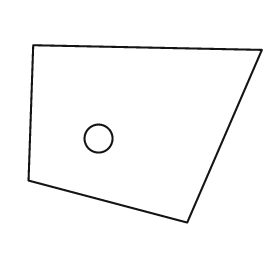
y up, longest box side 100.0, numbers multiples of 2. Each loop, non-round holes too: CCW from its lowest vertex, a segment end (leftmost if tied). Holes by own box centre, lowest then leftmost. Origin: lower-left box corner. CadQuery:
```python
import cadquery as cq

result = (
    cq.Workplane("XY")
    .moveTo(68.0, 0.0)
    .lineTo(100.0, 74.0)
    .lineTo(2.0, 76.0)
    .lineTo(0.0, 18.0)
    .close()
    .moveTo(30.0, 36.0)
    .circle(6.0)
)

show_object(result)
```